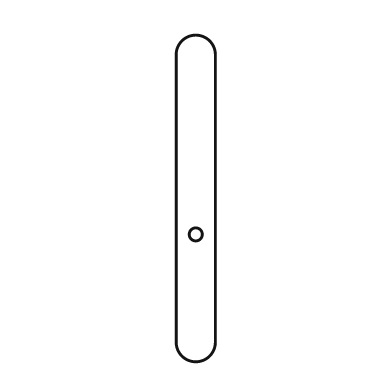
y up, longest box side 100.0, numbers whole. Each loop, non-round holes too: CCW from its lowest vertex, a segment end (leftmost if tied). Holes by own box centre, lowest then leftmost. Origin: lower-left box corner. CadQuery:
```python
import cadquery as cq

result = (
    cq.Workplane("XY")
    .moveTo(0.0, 6.0)
    .threePointArc((6.0, 0.0), (12.0, 6.0))
    .lineTo(12.0, 94.0)
    .threePointArc((6.0, 100.0), (0.0, 94.0))
    .close()
    .moveTo(6.0, 39.0)
    .circle(2.0)
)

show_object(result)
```